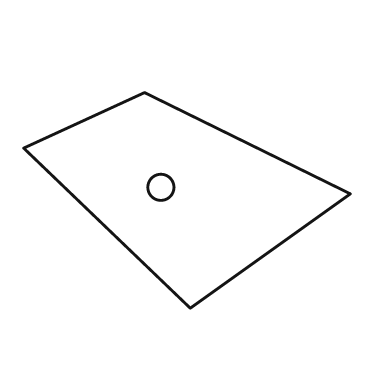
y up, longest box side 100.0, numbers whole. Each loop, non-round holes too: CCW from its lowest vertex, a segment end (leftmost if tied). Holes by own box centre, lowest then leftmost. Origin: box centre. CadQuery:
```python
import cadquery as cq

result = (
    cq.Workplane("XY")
    .moveTo(1.0, -33.0)
    .lineTo(50.0, 2.0)
    .lineTo(-13.0, 33.0)
    .lineTo(-50.0, 16.0)
    .close()
    .moveTo(-8.0, 4.0)
    .circle(4.0)
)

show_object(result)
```